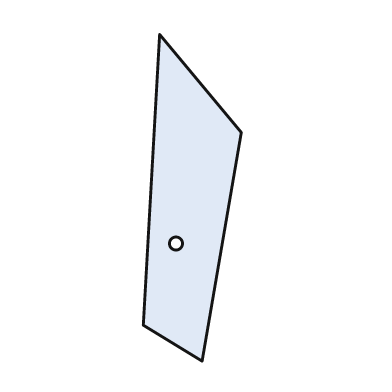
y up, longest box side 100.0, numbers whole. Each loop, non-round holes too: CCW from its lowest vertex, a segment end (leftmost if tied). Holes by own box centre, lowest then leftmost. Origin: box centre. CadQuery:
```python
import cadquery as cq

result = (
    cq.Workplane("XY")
    .moveTo(3.0, -50.0)
    .lineTo(15.0, 20.0)
    .lineTo(-10.0, 50.0)
    .lineTo(-15.0, -39.0)
    .close()
    .moveTo(-5.0, -14.0)
    .circle(2.0)
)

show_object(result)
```